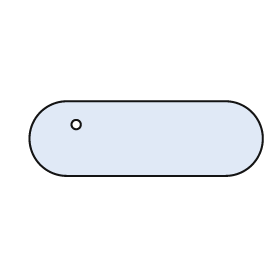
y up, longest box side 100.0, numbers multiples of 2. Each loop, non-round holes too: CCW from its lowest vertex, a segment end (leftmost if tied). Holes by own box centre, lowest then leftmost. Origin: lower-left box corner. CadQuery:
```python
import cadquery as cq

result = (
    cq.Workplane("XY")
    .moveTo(16.0, 0.0)
    .lineTo(84.0, 0.0)
    .threePointArc((100.0, 16.0), (84.0, 32.0))
    .lineTo(16.0, 32.0)
    .threePointArc((0.0, 16.0), (16.0, 0.0))
    .close()
    .moveTo(20.0, 22.0)
    .circle(2.0)
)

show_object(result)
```